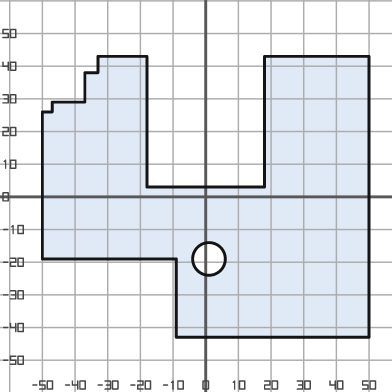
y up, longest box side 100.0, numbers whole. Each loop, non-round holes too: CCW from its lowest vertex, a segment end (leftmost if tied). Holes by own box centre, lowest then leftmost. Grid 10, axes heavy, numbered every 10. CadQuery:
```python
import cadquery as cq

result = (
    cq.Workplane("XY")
    .moveTo(-9.0, -43.0)
    .lineTo(50.0, -43.0)
    .lineTo(50.0, 43.0)
    .lineTo(18.0, 43.0)
    .lineTo(18.0, 3.0)
    .lineTo(-18.0, 3.0)
    .lineTo(-18.0, 43.0)
    .lineTo(-33.0, 43.0)
    .lineTo(-33.0, 38.0)
    .lineTo(-37.0, 38.0)
    .lineTo(-37.0, 29.0)
    .lineTo(-47.0, 29.0)
    .lineTo(-47.0, 26.0)
    .lineTo(-50.0, 26.0)
    .lineTo(-50.0, -19.0)
    .lineTo(-9.0, -19.0)
    .close()
    .moveTo(1.0, -19.0)
    .circle(5.0)
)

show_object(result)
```